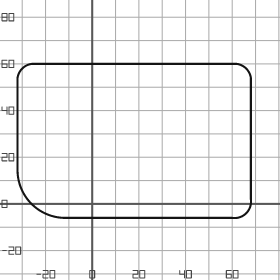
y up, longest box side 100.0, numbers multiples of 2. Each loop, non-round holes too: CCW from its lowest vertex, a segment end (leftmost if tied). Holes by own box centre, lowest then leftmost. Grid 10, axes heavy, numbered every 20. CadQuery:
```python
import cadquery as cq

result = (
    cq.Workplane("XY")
    .moveTo(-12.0, -6.0)
    .lineTo(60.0, -6.0)
    .threePointArc((66.0, -4.0), (68.0, 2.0))
    .lineTo(68.0, 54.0)
    .threePointArc((66.0, 58.0), (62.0, 60.0))
    .lineTo(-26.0, 60.0)
    .threePointArc((-30.0, 58.0), (-32.0, 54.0))
    .lineTo(-32.0, 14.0)
    .threePointArc((-26.0, 0.0), (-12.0, -6.0))
    .close()
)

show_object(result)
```